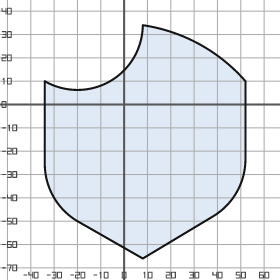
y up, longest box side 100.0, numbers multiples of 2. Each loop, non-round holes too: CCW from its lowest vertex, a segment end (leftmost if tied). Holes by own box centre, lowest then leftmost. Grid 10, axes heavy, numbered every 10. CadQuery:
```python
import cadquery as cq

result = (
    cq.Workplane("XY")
    .moveTo(8.0, -66.0)
    .lineTo(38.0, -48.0)
    .threePointArc((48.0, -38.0), (52.0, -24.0))
    .lineTo(52.0, 10.0)
    .threePointArc((32.0, 26.0), (8.0, 34.0))
    .threePointArc((-6.0, 10.0), (-34.0, 10.0))
    .lineTo(-34.0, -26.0)
    .threePointArc((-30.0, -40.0), (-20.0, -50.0))
    .close()
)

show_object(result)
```